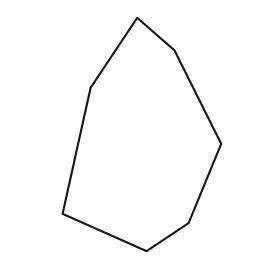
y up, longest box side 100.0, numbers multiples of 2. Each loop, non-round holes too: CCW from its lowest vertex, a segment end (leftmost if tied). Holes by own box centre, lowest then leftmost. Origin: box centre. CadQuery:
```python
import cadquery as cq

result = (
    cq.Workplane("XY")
    .moveTo(2.0, -50.0)
    .lineTo(20.0, -38.0)
    .lineTo(34.0, -4.0)
    .lineTo(14.0, 36.0)
    .lineTo(-2.0, 50.0)
    .lineTo(-22.0, 20.0)
    .lineTo(-34.0, -34.0)
    .close()
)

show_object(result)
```